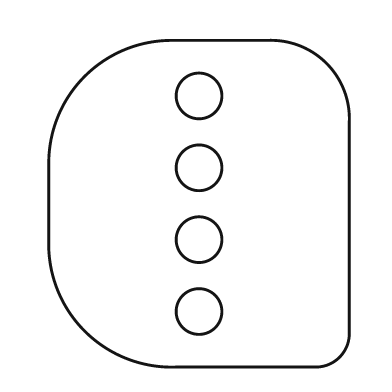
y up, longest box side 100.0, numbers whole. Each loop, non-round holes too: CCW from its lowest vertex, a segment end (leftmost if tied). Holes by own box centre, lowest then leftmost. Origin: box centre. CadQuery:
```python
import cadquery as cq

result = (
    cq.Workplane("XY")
    .moveTo(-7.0, -50.0)
    .lineTo(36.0, -50.0)
    .threePointArc((43.0, -47.0), (46.0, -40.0))
    .lineTo(46.0, 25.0)
    .threePointArc((39.0, 43.0), (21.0, 50.0))
    .lineTo(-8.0, 50.0)
    .threePointArc((-35.0, 39.0), (-46.0, 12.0))
    .lineTo(-46.0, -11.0)
    .threePointArc((-35.0, -39.0), (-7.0, -50.0))
    .close()
    .moveTo(0.0, -33.0)
    .circle(7.0)
    .moveTo(0.0, -11.0)
    .circle(7.0)
    .moveTo(0.0, 11.0)
    .circle(7.0)
    .moveTo(0.0, 33.0)
    .circle(7.0)
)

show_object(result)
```